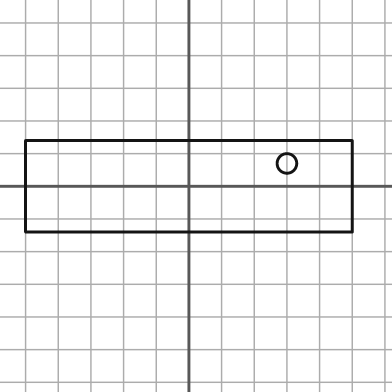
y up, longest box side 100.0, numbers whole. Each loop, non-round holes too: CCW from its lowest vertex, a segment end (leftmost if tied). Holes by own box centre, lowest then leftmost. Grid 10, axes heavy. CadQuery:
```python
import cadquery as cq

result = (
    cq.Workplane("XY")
    .moveTo(-50.0, -14.0)
    .lineTo(50.0, -14.0)
    .lineTo(50.0, 14.0)
    .lineTo(-50.0, 14.0)
    .close()
    .moveTo(30.0, 7.0)
    .circle(3.0)
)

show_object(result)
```